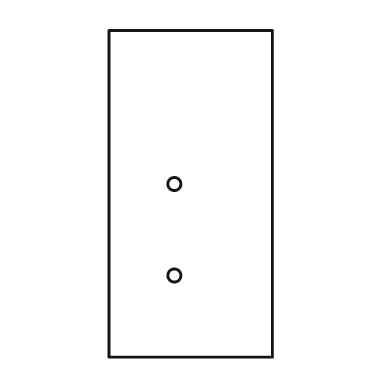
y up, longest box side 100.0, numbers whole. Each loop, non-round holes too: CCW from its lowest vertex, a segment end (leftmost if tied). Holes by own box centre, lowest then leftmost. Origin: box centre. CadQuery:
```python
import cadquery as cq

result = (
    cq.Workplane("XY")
    .moveTo(-25.0, -50.0)
    .lineTo(25.0, -50.0)
    .lineTo(25.0, 50.0)
    .lineTo(-25.0, 50.0)
    .close()
    .moveTo(-5.0, -25.0)
    .circle(2.0)
    .moveTo(-5.0, 3.0)
    .circle(2.0)
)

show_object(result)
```